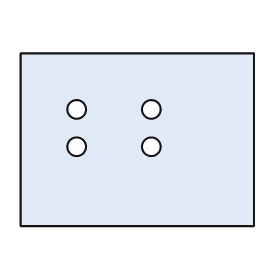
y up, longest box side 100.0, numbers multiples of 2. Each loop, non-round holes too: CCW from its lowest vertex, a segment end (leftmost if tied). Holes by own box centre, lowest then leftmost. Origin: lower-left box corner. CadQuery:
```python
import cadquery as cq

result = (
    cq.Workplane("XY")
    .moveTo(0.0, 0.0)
    .lineTo(100.0, 0.0)
    .lineTo(100.0, 74.0)
    .lineTo(0.0, 74.0)
    .close()
    .moveTo(24.0, 34.0)
    .circle(4.0)
    .moveTo(56.0, 34.0)
    .circle(4.0)
    .moveTo(24.0, 50.0)
    .circle(4.0)
    .moveTo(56.0, 50.0)
    .circle(4.0)
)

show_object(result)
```